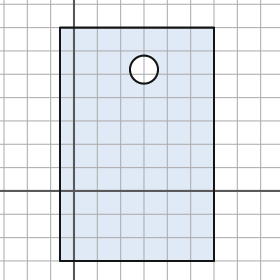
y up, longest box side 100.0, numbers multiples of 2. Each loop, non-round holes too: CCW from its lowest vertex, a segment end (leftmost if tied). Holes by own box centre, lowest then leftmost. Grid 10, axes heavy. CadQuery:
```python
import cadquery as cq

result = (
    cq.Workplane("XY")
    .moveTo(-6.0, -30.0)
    .lineTo(60.0, -30.0)
    .lineTo(60.0, 70.0)
    .lineTo(-6.0, 70.0)
    .close()
    .moveTo(30.0, 52.0)
    .circle(6.0)
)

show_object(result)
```